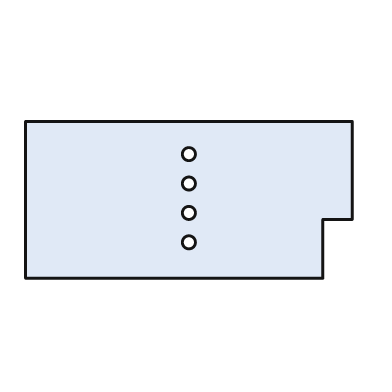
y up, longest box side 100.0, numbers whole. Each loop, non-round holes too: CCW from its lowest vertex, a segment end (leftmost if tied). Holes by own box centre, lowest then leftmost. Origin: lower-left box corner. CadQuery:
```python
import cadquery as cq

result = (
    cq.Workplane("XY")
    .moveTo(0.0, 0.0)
    .lineTo(91.0, 0.0)
    .lineTo(91.0, 18.0)
    .lineTo(100.0, 18.0)
    .lineTo(100.0, 48.0)
    .lineTo(0.0, 48.0)
    .close()
    .moveTo(50.0, 11.0)
    .circle(2.0)
    .moveTo(50.0, 20.0)
    .circle(2.0)
    .moveTo(50.0, 29.0)
    .circle(2.0)
    .moveTo(50.0, 38.0)
    .circle(2.0)
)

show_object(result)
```